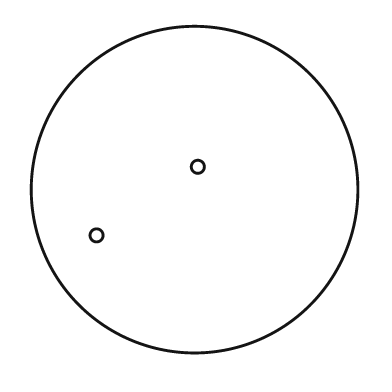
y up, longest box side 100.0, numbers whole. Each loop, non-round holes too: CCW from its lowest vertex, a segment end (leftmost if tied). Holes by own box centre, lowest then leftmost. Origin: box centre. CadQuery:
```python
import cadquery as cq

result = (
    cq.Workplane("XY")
    .moveTo(0.0, 0.0)
    .circle(50.0)
    .moveTo(-30.0, -14.0)
    .circle(2.0)
    .moveTo(1.0, 7.0)
    .circle(2.0)
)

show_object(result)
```